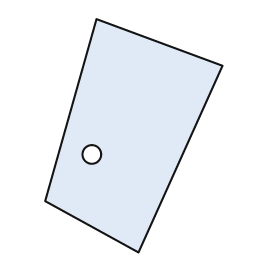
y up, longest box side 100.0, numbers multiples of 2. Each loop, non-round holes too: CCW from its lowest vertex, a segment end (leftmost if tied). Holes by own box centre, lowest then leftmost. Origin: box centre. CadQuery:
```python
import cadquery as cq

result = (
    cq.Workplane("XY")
    .moveTo(2.0, -50.0)
    .lineTo(38.0, 30.0)
    .lineTo(-16.0, 50.0)
    .lineTo(-38.0, -28.0)
    .close()
    .moveTo(-18.0, -8.0)
    .circle(4.0)
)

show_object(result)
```